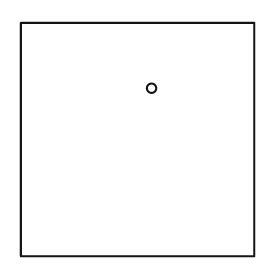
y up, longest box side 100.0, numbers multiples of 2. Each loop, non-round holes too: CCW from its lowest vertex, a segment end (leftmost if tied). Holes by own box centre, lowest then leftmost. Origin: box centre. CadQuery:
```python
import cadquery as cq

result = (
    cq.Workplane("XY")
    .moveTo(-50.0, -50.0)
    .lineTo(50.0, -50.0)
    .lineTo(50.0, 50.0)
    .lineTo(-50.0, 50.0)
    .close()
    .moveTo(6.0, 22.0)
    .circle(2.0)
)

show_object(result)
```